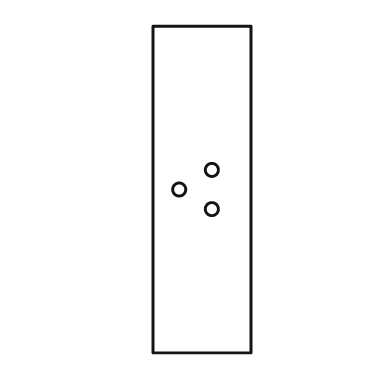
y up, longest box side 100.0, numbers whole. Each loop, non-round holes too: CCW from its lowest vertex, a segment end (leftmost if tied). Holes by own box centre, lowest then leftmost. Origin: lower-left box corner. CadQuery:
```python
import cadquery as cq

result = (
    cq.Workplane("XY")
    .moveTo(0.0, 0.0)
    .lineTo(30.0, 0.0)
    .lineTo(30.0, 100.0)
    .lineTo(0.0, 100.0)
    .close()
    .moveTo(18.0, 44.0)
    .circle(2.0)
    .moveTo(8.0, 50.0)
    .circle(2.0)
    .moveTo(18.0, 56.0)
    .circle(2.0)
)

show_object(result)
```